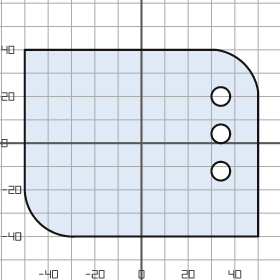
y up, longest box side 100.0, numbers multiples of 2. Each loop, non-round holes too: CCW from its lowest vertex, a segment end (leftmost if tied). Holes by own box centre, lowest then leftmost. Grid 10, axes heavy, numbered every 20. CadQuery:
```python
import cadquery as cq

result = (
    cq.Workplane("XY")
    .moveTo(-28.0, -40.0)
    .lineTo(50.0, -40.0)
    .lineTo(50.0, 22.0)
    .threePointArc((44.0, 34.0), (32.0, 40.0))
    .lineTo(-50.0, 40.0)
    .lineTo(-50.0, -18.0)
    .threePointArc((-44.0, -34.0), (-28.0, -40.0))
    .close()
    .moveTo(34.0, -12.0)
    .circle(4.0)
    .moveTo(34.0, 4.0)
    .circle(4.0)
    .moveTo(34.0, 20.0)
    .circle(4.0)
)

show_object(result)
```